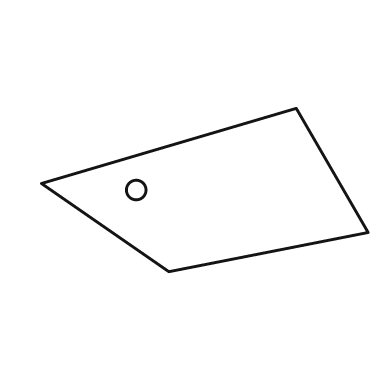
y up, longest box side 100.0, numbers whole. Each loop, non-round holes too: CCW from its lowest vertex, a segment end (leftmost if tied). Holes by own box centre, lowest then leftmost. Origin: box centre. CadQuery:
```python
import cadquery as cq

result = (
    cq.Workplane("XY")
    .moveTo(-11.0, -25.0)
    .lineTo(50.0, -13.0)
    .lineTo(28.0, 25.0)
    .lineTo(-50.0, 2.0)
    .close()
    .moveTo(-21.0, 0.0)
    .circle(3.0)
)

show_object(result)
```